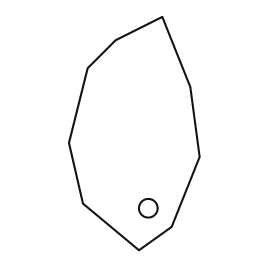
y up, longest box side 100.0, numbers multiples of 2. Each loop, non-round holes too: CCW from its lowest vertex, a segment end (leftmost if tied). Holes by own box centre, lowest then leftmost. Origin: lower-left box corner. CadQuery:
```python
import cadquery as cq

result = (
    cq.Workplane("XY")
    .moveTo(30.0, 0.0)
    .lineTo(44.0, 10.0)
    .lineTo(56.0, 40.0)
    .lineTo(52.0, 70.0)
    .lineTo(40.0, 100.0)
    .lineTo(20.0, 90.0)
    .lineTo(8.0, 78.0)
    .lineTo(0.0, 46.0)
    .lineTo(6.0, 20.0)
    .close()
    .moveTo(34.0, 18.0)
    .circle(4.0)
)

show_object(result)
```